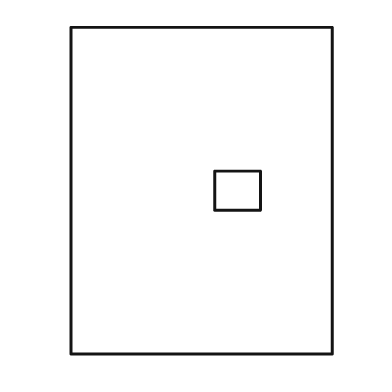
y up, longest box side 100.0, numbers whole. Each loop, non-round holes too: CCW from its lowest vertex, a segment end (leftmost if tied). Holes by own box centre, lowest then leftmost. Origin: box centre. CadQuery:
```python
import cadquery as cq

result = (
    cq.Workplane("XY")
    .moveTo(-40.0, -50.0)
    .lineTo(40.0, -50.0)
    .lineTo(40.0, 50.0)
    .lineTo(-40.0, 50.0)
    .close()
    .moveTo(4.0, -6.0)
    .lineTo(18.0, -6.0)
    .lineTo(18.0, 6.0)
    .lineTo(4.0, 6.0)
    .close()
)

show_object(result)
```